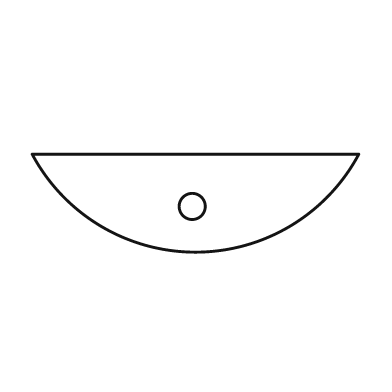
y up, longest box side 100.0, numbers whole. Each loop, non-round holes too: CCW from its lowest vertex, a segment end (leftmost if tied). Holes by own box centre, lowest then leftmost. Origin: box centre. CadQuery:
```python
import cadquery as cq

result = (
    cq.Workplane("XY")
    .moveTo(-50.0, 15.0)
    .threePointArc((0.0, -15.0), (50.0, 15.0))
    .close()
    .moveTo(-1.0, -1.0)
    .circle(4.0)
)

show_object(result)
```